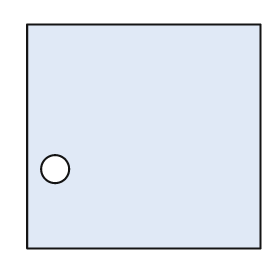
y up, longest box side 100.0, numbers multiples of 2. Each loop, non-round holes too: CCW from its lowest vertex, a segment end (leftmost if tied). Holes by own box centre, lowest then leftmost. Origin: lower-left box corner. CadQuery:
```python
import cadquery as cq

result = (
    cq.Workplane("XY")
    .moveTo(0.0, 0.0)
    .lineTo(100.0, 0.0)
    .lineTo(100.0, 96.0)
    .lineTo(0.0, 96.0)
    .close()
    .moveTo(12.0, 34.0)
    .circle(6.0)
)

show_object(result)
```